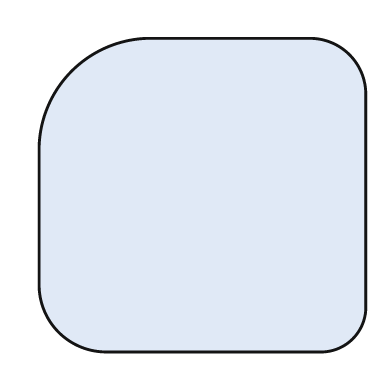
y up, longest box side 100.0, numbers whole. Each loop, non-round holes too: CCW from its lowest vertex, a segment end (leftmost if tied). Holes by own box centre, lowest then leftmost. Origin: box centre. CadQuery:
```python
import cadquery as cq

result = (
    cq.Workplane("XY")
    .moveTo(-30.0, -48.0)
    .lineTo(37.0, -48.0)
    .threePointArc((46.0, -44.0), (50.0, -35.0))
    .lineTo(50.0, 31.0)
    .threePointArc((45.0, 43.0), (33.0, 48.0))
    .lineTo(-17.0, 48.0)
    .threePointArc((-40.0, 38.0), (-50.0, 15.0))
    .lineTo(-50.0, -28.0)
    .threePointArc((-44.0, -42.0), (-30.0, -48.0))
    .close()
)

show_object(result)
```